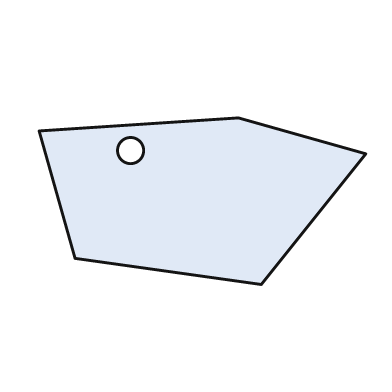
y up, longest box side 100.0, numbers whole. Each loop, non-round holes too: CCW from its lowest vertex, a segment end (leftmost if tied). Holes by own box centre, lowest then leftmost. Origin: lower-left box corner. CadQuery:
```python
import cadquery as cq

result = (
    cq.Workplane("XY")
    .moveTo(68.0, 0.0)
    .lineTo(100.0, 40.0)
    .lineTo(61.0, 51.0)
    .lineTo(0.0, 47.0)
    .lineTo(11.0, 8.0)
    .close()
    .moveTo(28.0, 41.0)
    .circle(4.0)
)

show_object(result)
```